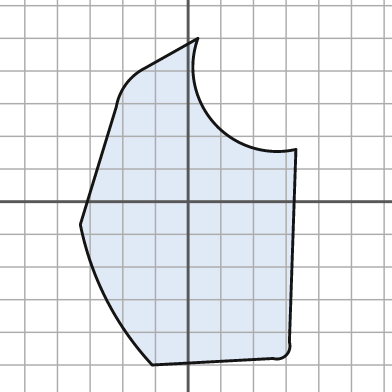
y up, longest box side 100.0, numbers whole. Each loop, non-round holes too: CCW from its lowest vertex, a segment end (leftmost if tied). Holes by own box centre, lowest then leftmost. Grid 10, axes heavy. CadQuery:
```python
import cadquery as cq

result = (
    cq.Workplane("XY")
    .moveTo(-11.0, -50.0)
    .lineTo(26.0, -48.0)
    .threePointArc((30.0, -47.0), (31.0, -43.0))
    .lineTo(33.0, 16.0)
    .threePointArc((8.0, 24.0), (3.0, 50.0))
    .lineTo(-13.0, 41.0)
    .threePointArc((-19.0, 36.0), (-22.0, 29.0))
    .lineTo(-33.0, -7.0)
    .threePointArc((-25.0, -30.0), (-11.0, -50.0))
    .close()
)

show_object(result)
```